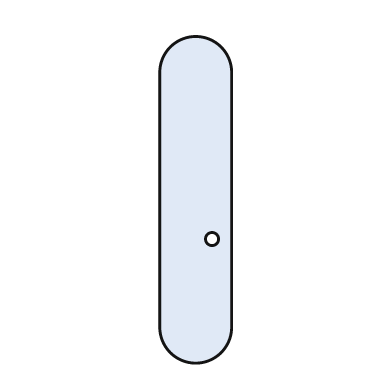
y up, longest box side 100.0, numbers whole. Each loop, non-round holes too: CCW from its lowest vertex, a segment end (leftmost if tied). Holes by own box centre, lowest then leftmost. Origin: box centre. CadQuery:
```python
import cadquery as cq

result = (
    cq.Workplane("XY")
    .moveTo(-11.0, -39.0)
    .threePointArc((0.0, -50.0), (11.0, -39.0))
    .lineTo(11.0, 39.0)
    .threePointArc((0.0, 50.0), (-11.0, 39.0))
    .close()
    .moveTo(5.0, -12.0)
    .circle(2.0)
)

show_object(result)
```